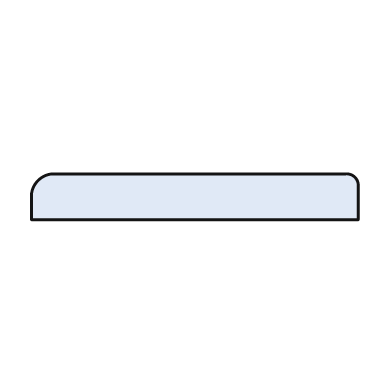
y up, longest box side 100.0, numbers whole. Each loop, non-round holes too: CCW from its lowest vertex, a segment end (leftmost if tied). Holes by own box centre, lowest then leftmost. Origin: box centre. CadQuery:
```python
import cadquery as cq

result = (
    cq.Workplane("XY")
    .moveTo(-50.0, -7.0)
    .lineTo(50.0, -7.0)
    .lineTo(50.0, 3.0)
    .threePointArc((49.0, 6.0), (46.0, 7.0))
    .lineTo(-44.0, 7.0)
    .threePointArc((-48.0, 5.0), (-50.0, 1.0))
    .close()
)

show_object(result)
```